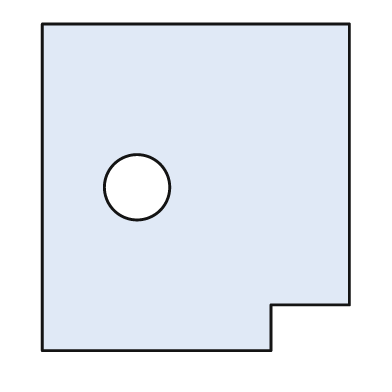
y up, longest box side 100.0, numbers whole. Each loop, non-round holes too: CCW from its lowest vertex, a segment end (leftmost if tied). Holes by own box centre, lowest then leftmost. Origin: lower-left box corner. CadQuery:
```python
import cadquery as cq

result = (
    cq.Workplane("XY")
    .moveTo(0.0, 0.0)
    .lineTo(70.0, 0.0)
    .lineTo(70.0, 14.0)
    .lineTo(94.0, 14.0)
    .lineTo(94.0, 100.0)
    .lineTo(0.0, 100.0)
    .close()
    .moveTo(29.0, 50.0)
    .circle(10.0)
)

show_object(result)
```